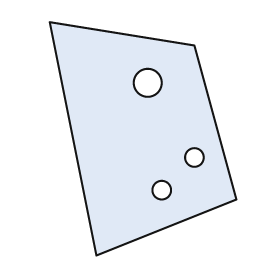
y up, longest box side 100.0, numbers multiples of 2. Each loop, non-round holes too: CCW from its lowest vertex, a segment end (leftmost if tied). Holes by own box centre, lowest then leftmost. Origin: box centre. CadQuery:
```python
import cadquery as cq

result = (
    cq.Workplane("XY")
    .moveTo(-20.0, -50.0)
    .lineTo(40.0, -26.0)
    .lineTo(22.0, 40.0)
    .lineTo(-40.0, 50.0)
    .close()
    .moveTo(8.0, -22.0)
    .circle(4.0)
    .moveTo(22.0, -8.0)
    .circle(4.0)
    .moveTo(2.0, 24.0)
    .circle(6.0)
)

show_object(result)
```